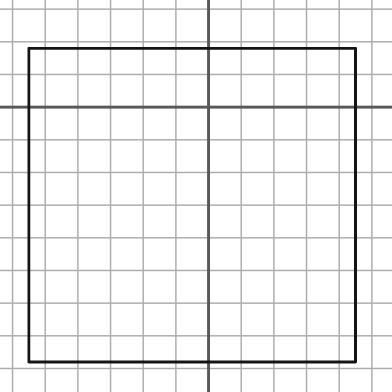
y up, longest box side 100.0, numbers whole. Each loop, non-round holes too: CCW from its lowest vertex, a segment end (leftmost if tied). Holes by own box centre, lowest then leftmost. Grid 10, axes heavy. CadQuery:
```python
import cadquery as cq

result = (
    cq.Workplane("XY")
    .moveTo(-55.0, -78.0)
    .lineTo(45.0, -78.0)
    .lineTo(45.0, 18.0)
    .lineTo(-55.0, 18.0)
    .close()
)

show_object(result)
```